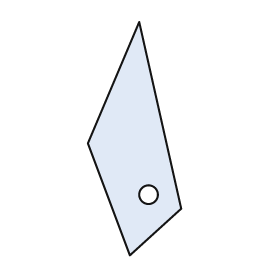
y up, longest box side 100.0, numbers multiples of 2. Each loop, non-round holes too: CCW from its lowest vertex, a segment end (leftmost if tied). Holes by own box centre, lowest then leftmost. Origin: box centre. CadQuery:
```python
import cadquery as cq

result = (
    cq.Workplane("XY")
    .moveTo(-2.0, -50.0)
    .lineTo(20.0, -30.0)
    .lineTo(2.0, 50.0)
    .lineTo(-20.0, -2.0)
    .close()
    .moveTo(6.0, -24.0)
    .circle(4.0)
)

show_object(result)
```